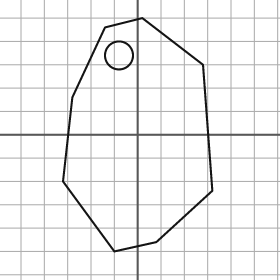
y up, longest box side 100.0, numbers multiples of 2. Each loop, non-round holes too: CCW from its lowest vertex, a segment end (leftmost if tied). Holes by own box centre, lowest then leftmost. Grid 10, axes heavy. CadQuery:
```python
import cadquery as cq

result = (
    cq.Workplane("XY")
    .moveTo(-10.0, -50.0)
    .lineTo(8.0, -46.0)
    .lineTo(32.0, -24.0)
    .lineTo(28.0, 30.0)
    .lineTo(2.0, 50.0)
    .lineTo(-14.0, 46.0)
    .lineTo(-28.0, 16.0)
    .lineTo(-32.0, -20.0)
    .close()
    .moveTo(-8.0, 34.0)
    .circle(6.0)
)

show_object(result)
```